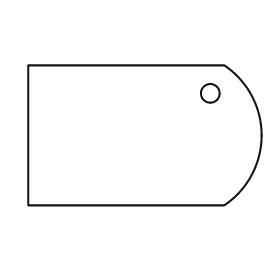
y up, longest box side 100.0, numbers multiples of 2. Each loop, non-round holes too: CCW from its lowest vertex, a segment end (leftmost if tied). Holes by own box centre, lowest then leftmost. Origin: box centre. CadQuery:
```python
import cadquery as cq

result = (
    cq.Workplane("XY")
    .moveTo(-50.0, -30.0)
    .lineTo(34.0, -30.0)
    .threePointArc((50.0, 0.0), (34.0, 30.0))
    .lineTo(-50.0, 30.0)
    .close()
    .moveTo(28.0, 18.0)
    .circle(4.0)
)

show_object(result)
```